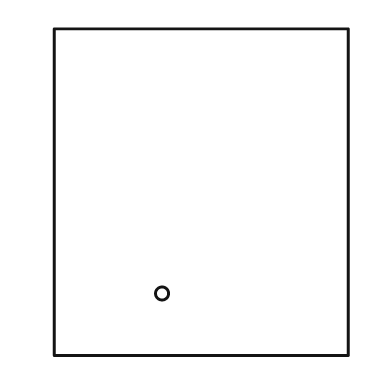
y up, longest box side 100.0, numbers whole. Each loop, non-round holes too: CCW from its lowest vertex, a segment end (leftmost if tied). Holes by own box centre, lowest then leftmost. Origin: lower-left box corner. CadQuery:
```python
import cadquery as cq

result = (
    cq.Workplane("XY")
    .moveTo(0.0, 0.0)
    .lineTo(90.0, 0.0)
    .lineTo(90.0, 100.0)
    .lineTo(0.0, 100.0)
    .close()
    .moveTo(33.0, 19.0)
    .circle(2.0)
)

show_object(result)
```